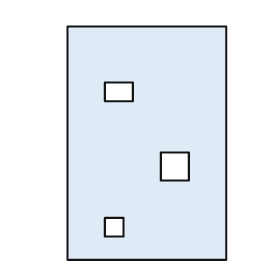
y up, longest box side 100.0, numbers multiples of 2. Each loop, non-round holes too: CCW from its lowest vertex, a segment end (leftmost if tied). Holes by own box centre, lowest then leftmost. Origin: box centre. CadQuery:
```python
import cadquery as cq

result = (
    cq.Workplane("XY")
    .moveTo(-34.0, -50.0)
    .lineTo(34.0, -50.0)
    .lineTo(34.0, 50.0)
    .lineTo(-34.0, 50.0)
    .close()
    .moveTo(-18.0, -40.0)
    .lineTo(-10.0, -40.0)
    .lineTo(-10.0, -32.0)
    .lineTo(-18.0, -32.0)
    .close()
    .moveTo(6.0, -16.0)
    .lineTo(18.0, -16.0)
    .lineTo(18.0, -4.0)
    .lineTo(6.0, -4.0)
    .close()
    .moveTo(-18.0, 18.0)
    .lineTo(-6.0, 18.0)
    .lineTo(-6.0, 26.0)
    .lineTo(-18.0, 26.0)
    .close()
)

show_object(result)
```